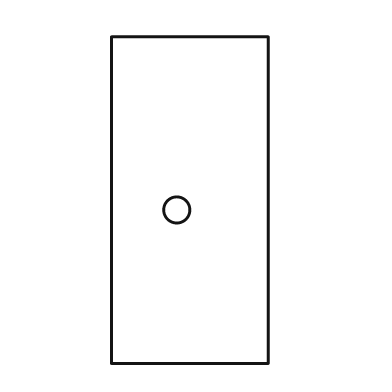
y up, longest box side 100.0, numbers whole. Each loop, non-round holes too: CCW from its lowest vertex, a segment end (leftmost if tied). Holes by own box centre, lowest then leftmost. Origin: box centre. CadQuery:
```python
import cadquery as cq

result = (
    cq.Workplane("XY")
    .moveTo(-24.0, -50.0)
    .lineTo(24.0, -50.0)
    .lineTo(24.0, 50.0)
    .lineTo(-24.0, 50.0)
    .close()
    .moveTo(-4.0, -3.0)
    .circle(4.0)
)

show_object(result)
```